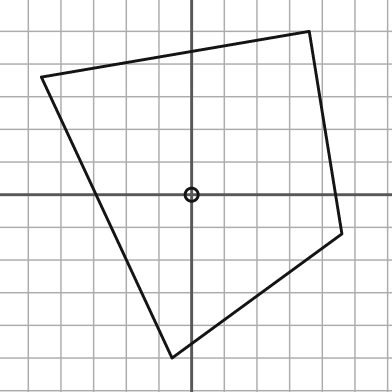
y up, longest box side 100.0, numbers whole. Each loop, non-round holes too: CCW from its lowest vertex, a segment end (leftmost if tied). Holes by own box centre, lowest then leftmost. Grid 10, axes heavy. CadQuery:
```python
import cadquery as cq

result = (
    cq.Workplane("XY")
    .moveTo(-6.0, -50.0)
    .lineTo(46.0, -12.0)
    .lineTo(36.0, 50.0)
    .lineTo(-46.0, 36.0)
    .close()
    .moveTo(0.0, 0.0)
    .circle(2.0)
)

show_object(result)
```